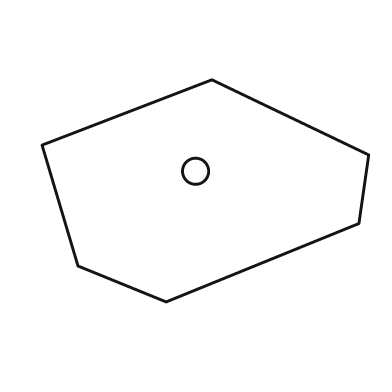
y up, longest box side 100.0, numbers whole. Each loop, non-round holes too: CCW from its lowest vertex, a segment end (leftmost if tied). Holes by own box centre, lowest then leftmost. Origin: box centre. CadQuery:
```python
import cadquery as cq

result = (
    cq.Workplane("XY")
    .moveTo(-12.0, -34.0)
    .lineTo(47.0, -10.0)
    .lineTo(50.0, 11.0)
    .lineTo(2.0, 34.0)
    .lineTo(-50.0, 14.0)
    .lineTo(-39.0, -23.0)
    .close()
    .moveTo(-3.0, 6.0)
    .circle(4.0)
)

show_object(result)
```